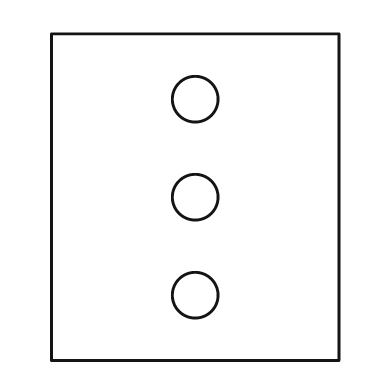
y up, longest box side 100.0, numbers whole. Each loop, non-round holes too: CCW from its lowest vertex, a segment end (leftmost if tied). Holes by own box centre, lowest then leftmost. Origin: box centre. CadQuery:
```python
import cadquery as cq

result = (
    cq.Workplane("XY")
    .moveTo(-44.0, -50.0)
    .lineTo(44.0, -50.0)
    .lineTo(44.0, 50.0)
    .lineTo(-44.0, 50.0)
    .close()
    .moveTo(0.0, -30.0)
    .circle(7.0)
    .moveTo(0.0, 0.0)
    .circle(7.0)
    .moveTo(0.0, 30.0)
    .circle(7.0)
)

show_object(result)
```